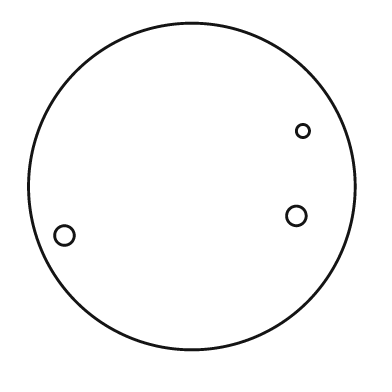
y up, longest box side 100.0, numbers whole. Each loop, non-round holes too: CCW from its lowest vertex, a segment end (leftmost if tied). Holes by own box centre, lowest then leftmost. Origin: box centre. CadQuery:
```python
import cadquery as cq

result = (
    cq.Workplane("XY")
    .moveTo(0.0, 0.0)
    .circle(50.0)
    .moveTo(-39.0, -15.0)
    .circle(3.0)
    .moveTo(32.0, -9.0)
    .circle(3.0)
    .moveTo(34.0, 17.0)
    .circle(2.0)
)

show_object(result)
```